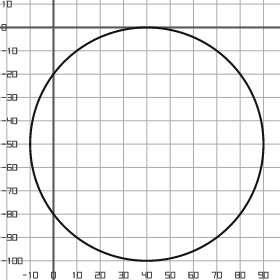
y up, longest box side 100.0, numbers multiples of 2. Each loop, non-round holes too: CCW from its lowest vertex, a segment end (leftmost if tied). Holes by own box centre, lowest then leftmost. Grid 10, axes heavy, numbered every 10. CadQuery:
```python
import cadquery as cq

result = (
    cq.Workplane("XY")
    .moveTo(40.0, -50.0)
    .circle(50.0)
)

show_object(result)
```